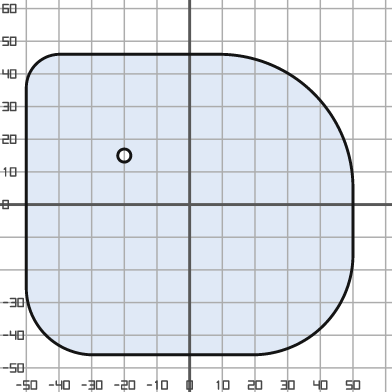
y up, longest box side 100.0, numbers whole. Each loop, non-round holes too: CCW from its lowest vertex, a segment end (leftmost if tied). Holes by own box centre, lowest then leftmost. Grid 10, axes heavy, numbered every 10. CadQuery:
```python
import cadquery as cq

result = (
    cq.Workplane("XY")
    .moveTo(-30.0, -46.0)
    .lineTo(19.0, -46.0)
    .threePointArc((41.0, -37.0), (50.0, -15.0))
    .lineTo(50.0, 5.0)
    .threePointArc((38.0, 34.0), (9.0, 46.0))
    .lineTo(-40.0, 46.0)
    .threePointArc((-47.0, 43.0), (-50.0, 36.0))
    .lineTo(-50.0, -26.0)
    .threePointArc((-44.0, -40.0), (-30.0, -46.0))
    .close()
    .moveTo(-20.0, 15.0)
    .circle(2.0)
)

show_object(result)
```